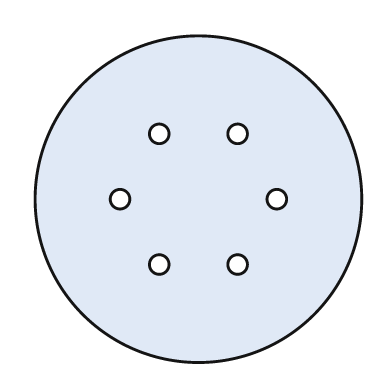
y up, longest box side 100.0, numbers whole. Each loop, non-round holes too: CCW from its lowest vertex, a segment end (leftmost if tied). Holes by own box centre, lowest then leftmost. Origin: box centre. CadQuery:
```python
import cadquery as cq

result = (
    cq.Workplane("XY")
    .moveTo(0.0, 0.0)
    .circle(50.0)
    .moveTo(-12.0, -20.0)
    .circle(3.0)
    .moveTo(12.0, -20.0)
    .circle(3.0)
    .moveTo(-24.0, 0.0)
    .circle(3.0)
    .moveTo(24.0, 0.0)
    .circle(3.0)
    .moveTo(-12.0, 20.0)
    .circle(3.0)
    .moveTo(12.0, 20.0)
    .circle(3.0)
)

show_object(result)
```